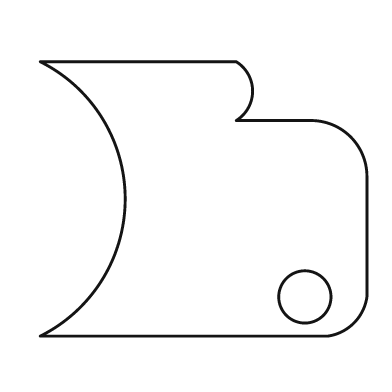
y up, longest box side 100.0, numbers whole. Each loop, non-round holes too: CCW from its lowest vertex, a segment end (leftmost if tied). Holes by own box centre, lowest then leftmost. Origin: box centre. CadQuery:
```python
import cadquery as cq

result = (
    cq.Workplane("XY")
    .moveTo(-50.0, -42.0)
    .lineTo(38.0, -42.0)
    .threePointArc((46.0, -38.0), (50.0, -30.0))
    .lineTo(50.0, 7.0)
    .threePointArc((45.0, 19.0), (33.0, 24.0))
    .lineTo(10.0, 24.0)
    .threePointArc((15.0, 33.0), (10.0, 42.0))
    .lineTo(-50.0, 42.0)
    .threePointArc((-24.0, 0.0), (-50.0, -42.0))
    .close()
    .moveTo(31.0, -30.0)
    .circle(8.0)
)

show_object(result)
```